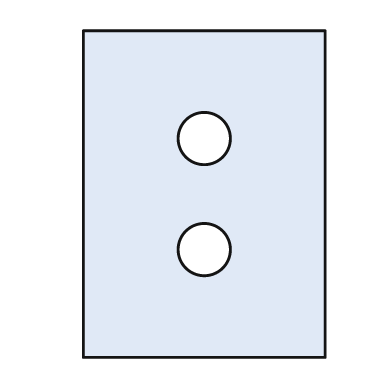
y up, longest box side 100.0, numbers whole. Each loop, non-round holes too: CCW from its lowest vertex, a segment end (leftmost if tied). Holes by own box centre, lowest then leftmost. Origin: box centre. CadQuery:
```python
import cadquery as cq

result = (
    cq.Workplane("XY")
    .moveTo(-37.0, -50.0)
    .lineTo(37.0, -50.0)
    .lineTo(37.0, 50.0)
    .lineTo(-37.0, 50.0)
    .close()
    .moveTo(0.0, -17.0)
    .circle(8.0)
    .moveTo(0.0, 17.0)
    .circle(8.0)
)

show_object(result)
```